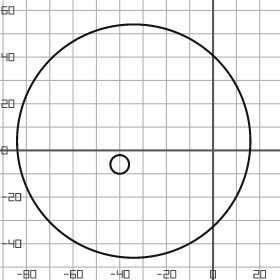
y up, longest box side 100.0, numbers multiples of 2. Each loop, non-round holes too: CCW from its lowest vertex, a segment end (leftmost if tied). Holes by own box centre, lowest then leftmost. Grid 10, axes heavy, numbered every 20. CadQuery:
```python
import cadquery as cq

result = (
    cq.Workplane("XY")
    .moveTo(-34.0, 4.0)
    .circle(50.0)
    .moveTo(-40.0, -6.0)
    .circle(4.0)
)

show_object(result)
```